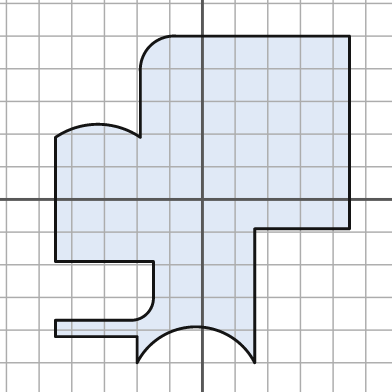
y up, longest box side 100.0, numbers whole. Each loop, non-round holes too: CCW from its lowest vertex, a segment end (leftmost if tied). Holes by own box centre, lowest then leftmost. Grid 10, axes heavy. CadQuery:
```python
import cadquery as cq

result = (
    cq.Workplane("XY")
    .moveTo(-20.0, -50.0)
    .threePointArc((-2.0, -39.0), (16.0, -50.0))
    .lineTo(16.0, -9.0)
    .lineTo(45.0, -9.0)
    .lineTo(45.0, 50.0)
    .lineTo(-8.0, 50.0)
    .threePointArc((-16.0, 47.0), (-19.0, 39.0))
    .lineTo(-19.0, 19.0)
    .threePointArc((-32.0, 23.0), (-45.0, 19.0))
    .lineTo(-45.0, -19.0)
    .lineTo(-15.0, -19.0)
    .lineTo(-15.0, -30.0)
    .threePointArc((-17.0, -35.0), (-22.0, -37.0))
    .lineTo(-45.0, -37.0)
    .lineTo(-45.0, -42.0)
    .lineTo(-20.0, -42.0)
    .close()
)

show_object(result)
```